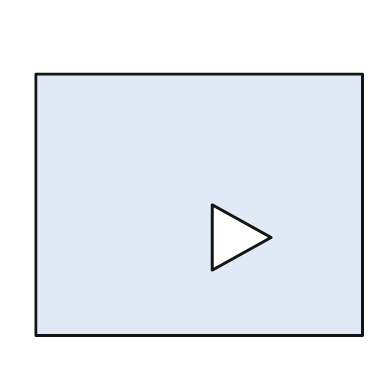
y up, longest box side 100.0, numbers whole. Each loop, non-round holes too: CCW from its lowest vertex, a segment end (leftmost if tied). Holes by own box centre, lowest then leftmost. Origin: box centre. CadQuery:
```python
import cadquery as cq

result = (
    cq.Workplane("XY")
    .moveTo(-50.0, -40.0)
    .lineTo(50.0, -40.0)
    .lineTo(50.0, 40.0)
    .lineTo(-50.0, 40.0)
    .close()
    .moveTo(4.0, -20.0)
    .lineTo(22.0, -10.0)
    .lineTo(4.0, 0.0)
    .close()
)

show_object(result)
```